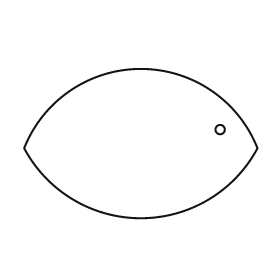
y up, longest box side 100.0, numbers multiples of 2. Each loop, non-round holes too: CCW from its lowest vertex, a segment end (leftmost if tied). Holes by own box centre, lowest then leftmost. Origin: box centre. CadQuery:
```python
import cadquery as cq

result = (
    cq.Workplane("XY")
    .moveTo(-50.0, -2.0)
    .threePointArc((0.0, -32.0), (50.0, -2.0))
    .threePointArc((0.0, 32.0), (-50.0, -2.0))
    .close()
    .moveTo(34.0, 6.0)
    .circle(2.0)
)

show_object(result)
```